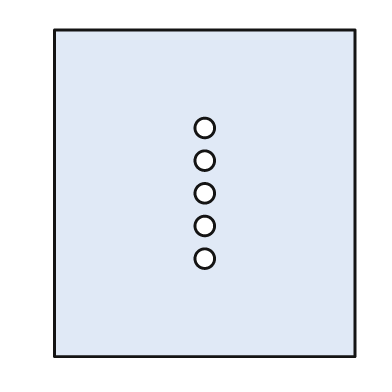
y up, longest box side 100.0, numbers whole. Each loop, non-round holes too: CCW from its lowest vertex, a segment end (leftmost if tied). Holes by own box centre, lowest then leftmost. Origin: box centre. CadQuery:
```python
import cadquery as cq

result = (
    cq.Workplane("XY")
    .moveTo(-46.0, -50.0)
    .lineTo(46.0, -50.0)
    .lineTo(46.0, 50.0)
    .lineTo(-46.0, 50.0)
    .close()
    .moveTo(0.0, -20.0)
    .circle(3.0)
    .moveTo(0.0, -10.0)
    .circle(3.0)
    .moveTo(0.0, 0.0)
    .circle(3.0)
    .moveTo(0.0, 10.0)
    .circle(3.0)
    .moveTo(0.0, 20.0)
    .circle(3.0)
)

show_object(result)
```